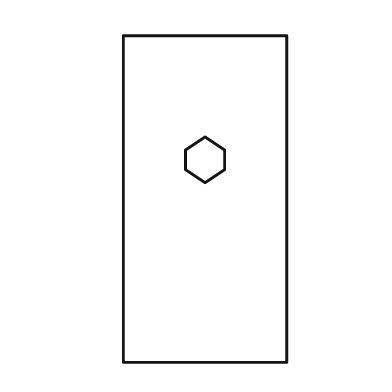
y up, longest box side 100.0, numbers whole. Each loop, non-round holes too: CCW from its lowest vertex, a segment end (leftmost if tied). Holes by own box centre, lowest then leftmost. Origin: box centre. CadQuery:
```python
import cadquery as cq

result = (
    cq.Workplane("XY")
    .moveTo(-25.0, -50.0)
    .lineTo(25.0, -50.0)
    .lineTo(25.0, 50.0)
    .lineTo(-25.0, 50.0)
    .close()
    .moveTo(0.0, 5.0)
    .lineTo(6.0, 9.0)
    .lineTo(6.0, 15.0)
    .lineTo(0.0, 19.0)
    .lineTo(-6.0, 15.0)
    .lineTo(-6.0, 9.0)
    .close()
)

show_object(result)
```